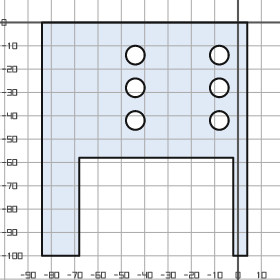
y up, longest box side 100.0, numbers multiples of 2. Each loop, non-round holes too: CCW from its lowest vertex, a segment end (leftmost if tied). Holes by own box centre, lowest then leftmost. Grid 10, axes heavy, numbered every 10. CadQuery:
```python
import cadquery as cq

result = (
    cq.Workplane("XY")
    .moveTo(-84.0, -100.0)
    .lineTo(-68.0, -100.0)
    .lineTo(-68.0, -58.0)
    .lineTo(-2.0, -58.0)
    .lineTo(-2.0, -100.0)
    .lineTo(4.0, -100.0)
    .lineTo(4.0, 0.0)
    .lineTo(-84.0, 0.0)
    .close()
    .moveTo(-44.0, -42.0)
    .circle(4.0)
    .moveTo(-8.0, -42.0)
    .circle(4.0)
    .moveTo(-44.0, -28.0)
    .circle(4.0)
    .moveTo(-8.0, -28.0)
    .circle(4.0)
    .moveTo(-44.0, -14.0)
    .circle(4.0)
    .moveTo(-8.0, -14.0)
    .circle(4.0)
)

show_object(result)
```